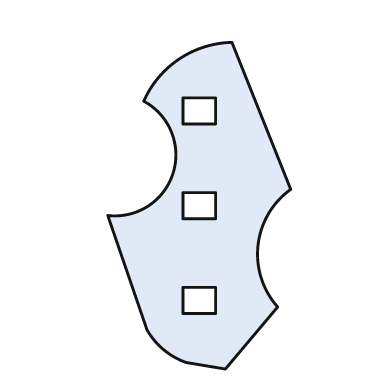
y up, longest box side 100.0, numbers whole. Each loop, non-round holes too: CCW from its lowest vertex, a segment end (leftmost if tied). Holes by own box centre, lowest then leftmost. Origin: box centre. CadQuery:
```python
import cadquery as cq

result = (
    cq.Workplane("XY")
    .moveTo(8.0, -50.0)
    .lineTo(24.0, -31.0)
    .threePointArc((18.0, -12.0), (28.0, 5.0))
    .lineTo(10.0, 50.0)
    .threePointArc((-6.0, 45.0), (-17.0, 32.0))
    .threePointArc((-8.0, 10.0), (-28.0, -3.0))
    .lineTo(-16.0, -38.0)
    .threePointArc((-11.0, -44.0), (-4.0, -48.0))
    .close()
    .moveTo(-5.0, -33.0)
    .lineTo(5.0, -33.0)
    .lineTo(5.0, -25.0)
    .lineTo(-5.0, -25.0)
    .close()
    .moveTo(-5.0, -4.0)
    .lineTo(5.0, -4.0)
    .lineTo(5.0, 4.0)
    .lineTo(-5.0, 4.0)
    .close()
    .moveTo(-5.0, 25.0)
    .lineTo(5.0, 25.0)
    .lineTo(5.0, 33.0)
    .lineTo(-5.0, 33.0)
    .close()
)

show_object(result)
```